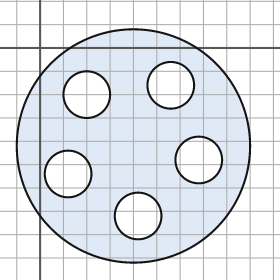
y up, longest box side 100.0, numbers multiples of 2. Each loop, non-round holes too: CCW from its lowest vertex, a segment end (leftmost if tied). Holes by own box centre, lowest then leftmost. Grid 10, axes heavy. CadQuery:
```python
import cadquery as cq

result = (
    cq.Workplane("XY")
    .moveTo(40.0, -42.0)
    .circle(50.0)
    .moveTo(42.0, -72.0)
    .circle(10.0)
    .moveTo(12.0, -54.0)
    .circle(10.0)
    .moveTo(68.0, -48.0)
    .circle(10.0)
    .moveTo(20.0, -20.0)
    .circle(10.0)
    .moveTo(56.0, -16.0)
    .circle(10.0)
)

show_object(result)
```